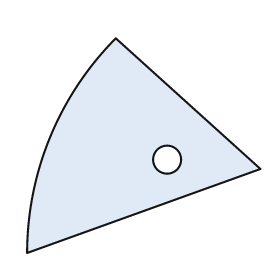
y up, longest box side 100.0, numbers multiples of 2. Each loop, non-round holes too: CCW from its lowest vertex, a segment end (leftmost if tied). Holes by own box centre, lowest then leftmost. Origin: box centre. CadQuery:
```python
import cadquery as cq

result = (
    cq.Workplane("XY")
    .moveTo(-50.0, -46.0)
    .lineTo(50.0, -10.0)
    .lineTo(-12.0, 46.0)
    .threePointArc((-40.0, 4.0), (-50.0, -46.0))
    .close()
    .moveTo(10.0, -6.0)
    .circle(6.0)
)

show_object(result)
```